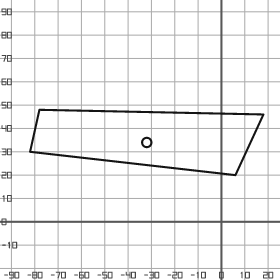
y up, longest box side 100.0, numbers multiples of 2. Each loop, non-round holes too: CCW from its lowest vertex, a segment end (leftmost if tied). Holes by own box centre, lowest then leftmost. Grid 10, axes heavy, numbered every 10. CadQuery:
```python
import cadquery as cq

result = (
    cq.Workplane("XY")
    .moveTo(6.0, 20.0)
    .lineTo(18.0, 46.0)
    .lineTo(-78.0, 48.0)
    .lineTo(-82.0, 30.0)
    .close()
    .moveTo(-32.0, 34.0)
    .circle(2.0)
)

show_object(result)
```